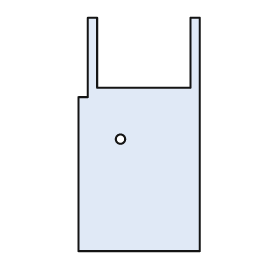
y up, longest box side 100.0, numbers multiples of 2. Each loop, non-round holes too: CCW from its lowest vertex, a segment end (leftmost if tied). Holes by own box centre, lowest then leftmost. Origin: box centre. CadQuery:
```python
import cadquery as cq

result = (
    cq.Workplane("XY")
    .moveTo(-26.0, -50.0)
    .lineTo(26.0, -50.0)
    .lineTo(26.0, 50.0)
    .lineTo(22.0, 50.0)
    .lineTo(22.0, 20.0)
    .lineTo(-18.0, 20.0)
    .lineTo(-18.0, 50.0)
    .lineTo(-22.0, 50.0)
    .lineTo(-22.0, 16.0)
    .lineTo(-26.0, 16.0)
    .close()
    .moveTo(-8.0, -2.0)
    .circle(2.0)
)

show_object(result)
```